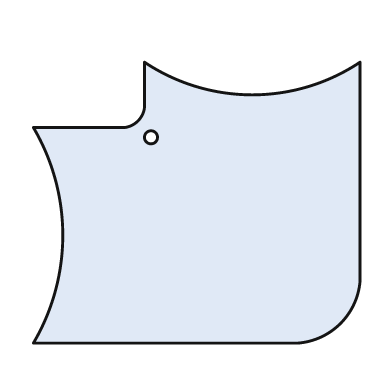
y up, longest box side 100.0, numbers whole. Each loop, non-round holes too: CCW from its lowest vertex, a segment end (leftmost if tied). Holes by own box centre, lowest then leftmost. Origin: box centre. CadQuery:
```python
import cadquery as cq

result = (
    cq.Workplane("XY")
    .moveTo(-50.0, -43.0)
    .lineTo(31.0, -43.0)
    .threePointArc((44.0, -37.0), (50.0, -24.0))
    .lineTo(50.0, 43.0)
    .threePointArc((17.0, 33.0), (-16.0, 43.0))
    .lineTo(-16.0, 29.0)
    .threePointArc((-18.0, 25.0), (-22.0, 23.0))
    .lineTo(-50.0, 23.0)
    .threePointArc((-41.0, -10.0), (-50.0, -43.0))
    .close()
    .moveTo(-14.0, 20.0)
    .circle(2.0)
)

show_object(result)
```